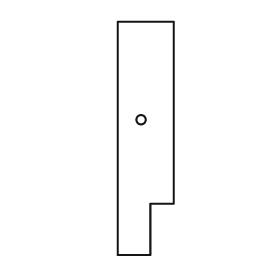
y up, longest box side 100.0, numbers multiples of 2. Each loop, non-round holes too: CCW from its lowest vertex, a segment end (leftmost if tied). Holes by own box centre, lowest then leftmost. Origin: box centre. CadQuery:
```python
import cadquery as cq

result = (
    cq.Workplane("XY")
    .moveTo(-12.0, -50.0)
    .lineTo(2.0, -50.0)
    .lineTo(2.0, -28.0)
    .lineTo(12.0, -28.0)
    .lineTo(12.0, 50.0)
    .lineTo(-12.0, 50.0)
    .close()
    .moveTo(-2.0, 8.0)
    .circle(2.0)
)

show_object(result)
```